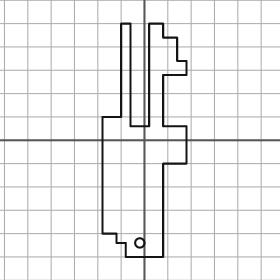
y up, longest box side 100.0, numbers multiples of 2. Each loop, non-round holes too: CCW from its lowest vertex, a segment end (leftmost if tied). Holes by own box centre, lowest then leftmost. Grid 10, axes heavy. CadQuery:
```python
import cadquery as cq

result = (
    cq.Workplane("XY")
    .moveTo(-8.0, -50.0)
    .lineTo(8.0, -50.0)
    .lineTo(8.0, -10.0)
    .lineTo(18.0, -10.0)
    .lineTo(18.0, 6.0)
    .lineTo(8.0, 6.0)
    .lineTo(8.0, 28.0)
    .lineTo(18.0, 28.0)
    .lineTo(18.0, 34.0)
    .lineTo(14.0, 34.0)
    .lineTo(14.0, 44.0)
    .lineTo(8.0, 44.0)
    .lineTo(8.0, 50.0)
    .lineTo(2.0, 50.0)
    .lineTo(2.0, 6.0)
    .lineTo(-6.0, 6.0)
    .lineTo(-6.0, 50.0)
    .lineTo(-10.0, 50.0)
    .lineTo(-10.0, 10.0)
    .lineTo(-18.0, 10.0)
    .lineTo(-18.0, -40.0)
    .lineTo(-12.0, -40.0)
    .lineTo(-12.0, -44.0)
    .lineTo(-8.0, -44.0)
    .close()
    .moveTo(-2.0, -44.0)
    .circle(2.0)
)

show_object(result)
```